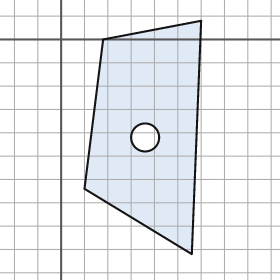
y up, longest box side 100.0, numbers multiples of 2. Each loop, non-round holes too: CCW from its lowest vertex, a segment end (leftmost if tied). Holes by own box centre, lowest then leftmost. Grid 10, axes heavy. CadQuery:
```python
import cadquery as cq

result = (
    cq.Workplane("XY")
    .moveTo(56.0, -92.0)
    .lineTo(60.0, 8.0)
    .lineTo(18.0, 0.0)
    .lineTo(10.0, -64.0)
    .close()
    .moveTo(36.0, -42.0)
    .circle(6.0)
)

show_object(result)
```